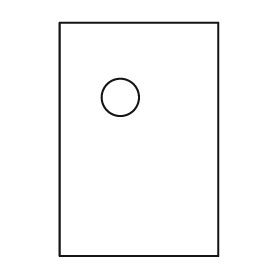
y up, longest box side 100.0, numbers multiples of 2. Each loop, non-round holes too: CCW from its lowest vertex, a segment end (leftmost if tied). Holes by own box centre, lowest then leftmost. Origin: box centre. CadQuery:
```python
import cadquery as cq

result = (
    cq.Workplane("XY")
    .moveTo(-34.0, -50.0)
    .lineTo(34.0, -50.0)
    .lineTo(34.0, 50.0)
    .lineTo(-34.0, 50.0)
    .close()
    .moveTo(-8.0, 18.0)
    .circle(8.0)
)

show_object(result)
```